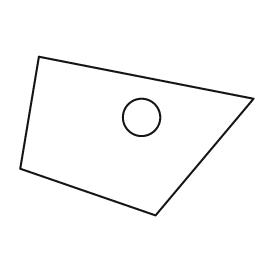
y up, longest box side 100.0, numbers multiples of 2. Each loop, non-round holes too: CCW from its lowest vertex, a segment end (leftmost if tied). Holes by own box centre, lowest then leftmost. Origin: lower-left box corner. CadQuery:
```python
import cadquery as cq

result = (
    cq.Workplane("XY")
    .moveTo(58.0, 0.0)
    .lineTo(100.0, 50.0)
    .lineTo(8.0, 68.0)
    .lineTo(0.0, 20.0)
    .close()
    .moveTo(52.0, 42.0)
    .circle(8.0)
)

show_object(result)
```